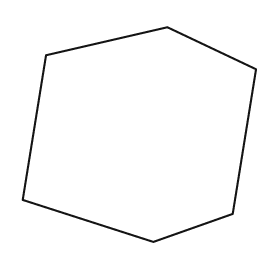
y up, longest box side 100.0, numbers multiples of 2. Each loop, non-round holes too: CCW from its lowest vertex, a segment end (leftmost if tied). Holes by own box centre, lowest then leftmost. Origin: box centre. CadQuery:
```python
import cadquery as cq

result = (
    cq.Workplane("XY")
    .moveTo(6.0, -46.0)
    .lineTo(40.0, -34.0)
    .lineTo(50.0, 28.0)
    .lineTo(12.0, 46.0)
    .lineTo(-40.0, 34.0)
    .lineTo(-50.0, -28.0)
    .close()
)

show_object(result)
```